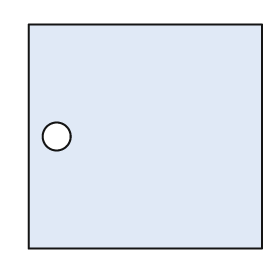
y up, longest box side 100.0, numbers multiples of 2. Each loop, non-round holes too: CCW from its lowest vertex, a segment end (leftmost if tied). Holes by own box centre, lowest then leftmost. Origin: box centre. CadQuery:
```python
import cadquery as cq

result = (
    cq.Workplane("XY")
    .moveTo(-50.0, -48.0)
    .lineTo(50.0, -48.0)
    .lineTo(50.0, 48.0)
    .lineTo(-50.0, 48.0)
    .close()
    .moveTo(-38.0, 0.0)
    .circle(6.0)
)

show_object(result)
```